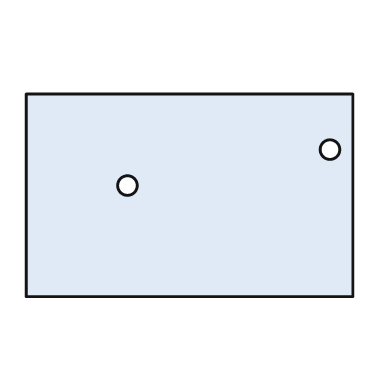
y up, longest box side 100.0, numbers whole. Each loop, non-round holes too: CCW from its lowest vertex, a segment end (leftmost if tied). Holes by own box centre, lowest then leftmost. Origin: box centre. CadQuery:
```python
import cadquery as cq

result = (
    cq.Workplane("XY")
    .moveTo(-50.0, -31.0)
    .lineTo(50.0, -31.0)
    .lineTo(50.0, 31.0)
    .lineTo(-50.0, 31.0)
    .close()
    .moveTo(-19.0, 3.0)
    .circle(3.0)
    .moveTo(43.0, 14.0)
    .circle(3.0)
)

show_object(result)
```